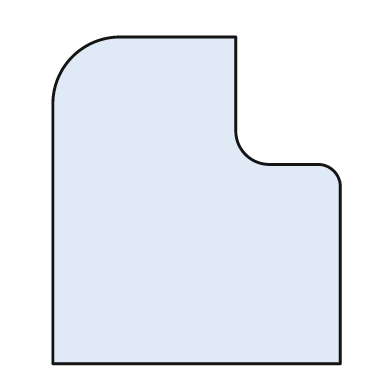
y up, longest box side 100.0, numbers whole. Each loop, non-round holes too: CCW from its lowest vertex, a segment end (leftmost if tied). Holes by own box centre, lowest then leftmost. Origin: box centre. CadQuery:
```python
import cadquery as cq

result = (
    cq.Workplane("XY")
    .moveTo(-44.0, -50.0)
    .lineTo(44.0, -50.0)
    .lineTo(44.0, 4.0)
    .threePointArc((42.0, 9.0), (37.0, 11.0))
    .lineTo(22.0, 11.0)
    .threePointArc((15.0, 14.0), (12.0, 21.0))
    .lineTo(12.0, 50.0)
    .lineTo(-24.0, 50.0)
    .threePointArc((-38.0, 44.0), (-44.0, 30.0))
    .close()
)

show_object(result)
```